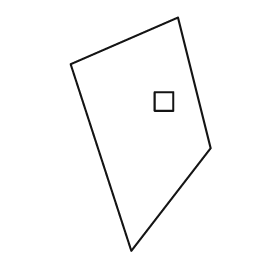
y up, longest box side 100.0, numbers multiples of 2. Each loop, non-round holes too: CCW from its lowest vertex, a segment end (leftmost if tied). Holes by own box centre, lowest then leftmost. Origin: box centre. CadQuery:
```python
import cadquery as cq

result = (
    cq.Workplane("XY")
    .moveTo(-4.0, -50.0)
    .lineTo(30.0, -6.0)
    .lineTo(16.0, 50.0)
    .lineTo(-30.0, 30.0)
    .close()
    .moveTo(6.0, 10.0)
    .lineTo(14.0, 10.0)
    .lineTo(14.0, 18.0)
    .lineTo(6.0, 18.0)
    .close()
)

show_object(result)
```